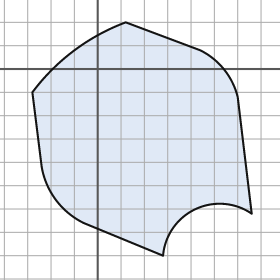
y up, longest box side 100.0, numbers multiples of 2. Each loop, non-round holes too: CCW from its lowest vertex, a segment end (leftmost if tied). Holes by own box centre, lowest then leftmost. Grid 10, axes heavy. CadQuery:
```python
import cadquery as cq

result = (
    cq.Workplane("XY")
    .moveTo(28.0, -80.0)
    .threePointArc((42.0, -60.0), (66.0, -62.0))
    .lineTo(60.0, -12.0)
    .threePointArc((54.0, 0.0), (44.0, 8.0))
    .lineTo(12.0, 20.0)
    .threePointArc((-10.0, 8.0), (-28.0, -10.0))
    .lineTo(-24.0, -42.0)
    .threePointArc((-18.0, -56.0), (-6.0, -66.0))
    .close()
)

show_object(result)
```